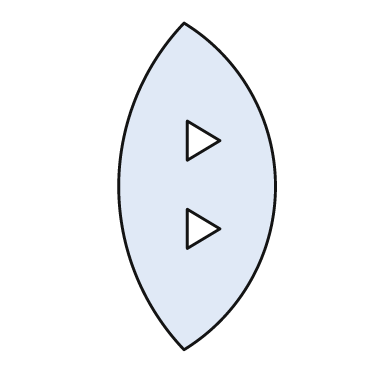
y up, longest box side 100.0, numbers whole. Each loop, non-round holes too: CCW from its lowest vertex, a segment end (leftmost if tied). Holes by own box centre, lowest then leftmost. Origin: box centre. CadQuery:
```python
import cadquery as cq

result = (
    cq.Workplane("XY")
    .moveTo(-4.0, -50.0)
    .threePointArc((24.0, 0.0), (-4.0, 50.0))
    .threePointArc((-24.0, 0.0), (-4.0, -50.0))
    .close()
    .moveTo(-3.0, -19.0)
    .lineTo(7.0, -13.0)
    .lineTo(-3.0, -7.0)
    .close()
    .moveTo(-3.0, 8.0)
    .lineTo(7.0, 14.0)
    .lineTo(-3.0, 20.0)
    .close()
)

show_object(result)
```